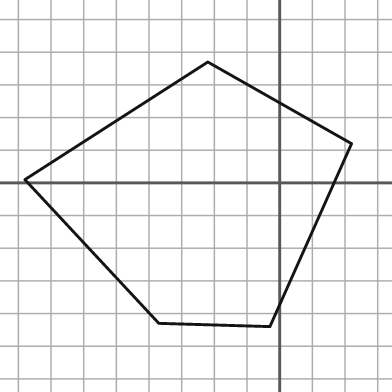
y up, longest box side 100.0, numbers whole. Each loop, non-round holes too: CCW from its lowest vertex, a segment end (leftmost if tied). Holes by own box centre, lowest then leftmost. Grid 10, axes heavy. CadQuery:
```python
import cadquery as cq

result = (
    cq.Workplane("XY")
    .moveTo(-3.0, -44.0)
    .lineTo(22.0, 12.0)
    .lineTo(-22.0, 37.0)
    .lineTo(-78.0, 1.0)
    .lineTo(-37.0, -43.0)
    .close()
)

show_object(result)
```